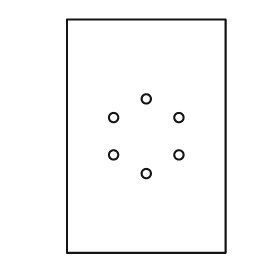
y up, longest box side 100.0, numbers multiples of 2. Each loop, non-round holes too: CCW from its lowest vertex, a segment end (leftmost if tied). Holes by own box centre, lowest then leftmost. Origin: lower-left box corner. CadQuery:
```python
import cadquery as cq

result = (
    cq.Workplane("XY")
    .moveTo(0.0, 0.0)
    .lineTo(68.0, 0.0)
    .lineTo(68.0, 100.0)
    .lineTo(0.0, 100.0)
    .close()
    .moveTo(34.0, 34.0)
    .circle(2.0)
    .moveTo(20.0, 42.0)
    .circle(2.0)
    .moveTo(48.0, 42.0)
    .circle(2.0)
    .moveTo(20.0, 58.0)
    .circle(2.0)
    .moveTo(48.0, 58.0)
    .circle(2.0)
    .moveTo(34.0, 66.0)
    .circle(2.0)
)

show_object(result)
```